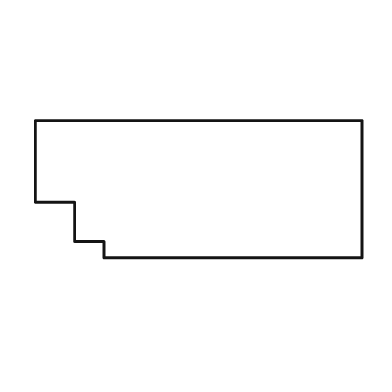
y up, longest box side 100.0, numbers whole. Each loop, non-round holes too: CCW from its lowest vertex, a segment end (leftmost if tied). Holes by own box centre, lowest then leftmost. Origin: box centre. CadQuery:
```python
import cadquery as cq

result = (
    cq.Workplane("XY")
    .moveTo(-29.0, -21.0)
    .lineTo(50.0, -21.0)
    .lineTo(50.0, 21.0)
    .lineTo(-50.0, 21.0)
    .lineTo(-50.0, -4.0)
    .lineTo(-38.0, -4.0)
    .lineTo(-38.0, -16.0)
    .lineTo(-29.0, -16.0)
    .close()
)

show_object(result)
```